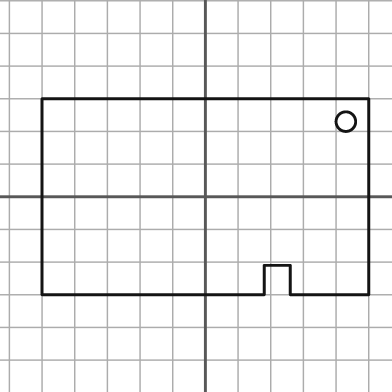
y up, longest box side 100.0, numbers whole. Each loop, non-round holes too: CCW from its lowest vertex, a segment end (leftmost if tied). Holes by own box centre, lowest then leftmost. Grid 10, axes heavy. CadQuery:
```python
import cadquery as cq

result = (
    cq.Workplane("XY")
    .moveTo(-50.0, -30.0)
    .lineTo(18.0, -30.0)
    .lineTo(18.0, -21.0)
    .lineTo(26.0, -21.0)
    .lineTo(26.0, -30.0)
    .lineTo(50.0, -30.0)
    .lineTo(50.0, 30.0)
    .lineTo(-50.0, 30.0)
    .close()
    .moveTo(43.0, 23.0)
    .circle(3.0)
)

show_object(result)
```